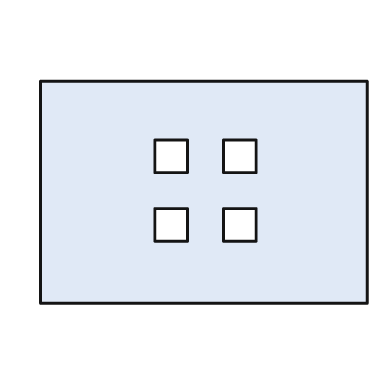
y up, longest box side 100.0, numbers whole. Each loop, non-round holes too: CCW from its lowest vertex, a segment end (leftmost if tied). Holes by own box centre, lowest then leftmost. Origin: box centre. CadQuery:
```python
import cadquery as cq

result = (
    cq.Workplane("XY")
    .moveTo(-50.0, -34.0)
    .lineTo(50.0, -34.0)
    .lineTo(50.0, 34.0)
    .lineTo(-50.0, 34.0)
    .close()
    .moveTo(-15.0, -15.0)
    .lineTo(-5.0, -15.0)
    .lineTo(-5.0, -5.0)
    .lineTo(-15.0, -5.0)
    .close()
    .moveTo(6.0, -15.0)
    .lineTo(16.0, -15.0)
    .lineTo(16.0, -5.0)
    .lineTo(6.0, -5.0)
    .close()
    .moveTo(-15.0, 6.0)
    .lineTo(-5.0, 6.0)
    .lineTo(-5.0, 16.0)
    .lineTo(-15.0, 16.0)
    .close()
    .moveTo(6.0, 6.0)
    .lineTo(16.0, 6.0)
    .lineTo(16.0, 16.0)
    .lineTo(6.0, 16.0)
    .close()
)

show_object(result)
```